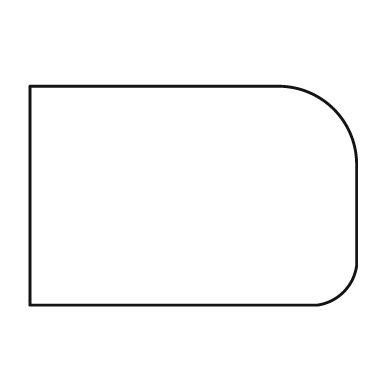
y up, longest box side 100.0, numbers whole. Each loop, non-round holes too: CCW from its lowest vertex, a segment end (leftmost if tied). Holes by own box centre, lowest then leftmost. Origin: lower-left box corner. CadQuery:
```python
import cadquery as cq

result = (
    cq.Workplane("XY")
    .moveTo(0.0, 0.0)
    .lineTo(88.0, 0.0)
    .threePointArc((96.0, 4.0), (100.0, 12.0))
    .lineTo(100.0, 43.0)
    .threePointArc((93.0, 60.0), (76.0, 67.0))
    .lineTo(0.0, 67.0)
    .close()
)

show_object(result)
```